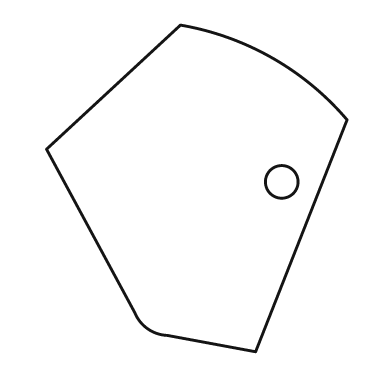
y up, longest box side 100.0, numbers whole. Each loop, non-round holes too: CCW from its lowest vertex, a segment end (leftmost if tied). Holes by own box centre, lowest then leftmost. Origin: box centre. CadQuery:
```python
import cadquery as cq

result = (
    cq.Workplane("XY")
    .moveTo(18.0, -50.0)
    .lineTo(46.0, 21.0)
    .threePointArc((23.0, 40.0), (-5.0, 50.0))
    .lineTo(-46.0, 12.0)
    .lineTo(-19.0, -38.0)
    .threePointArc((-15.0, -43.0), (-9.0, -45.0))
    .close()
    .moveTo(26.0, 2.0)
    .circle(5.0)
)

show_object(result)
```